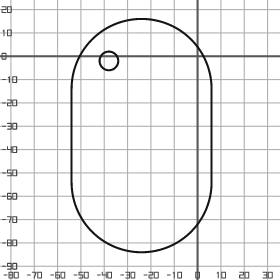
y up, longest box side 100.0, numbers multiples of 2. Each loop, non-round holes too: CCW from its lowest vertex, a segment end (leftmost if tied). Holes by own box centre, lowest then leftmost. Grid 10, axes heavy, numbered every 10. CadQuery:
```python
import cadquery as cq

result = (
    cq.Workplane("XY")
    .moveTo(-54.0, -54.0)
    .threePointArc((-24.0, -84.0), (6.0, -54.0))
    .lineTo(6.0, -14.0)
    .threePointArc((-24.0, 16.0), (-54.0, -14.0))
    .close()
    .moveTo(-38.0, -2.0)
    .circle(4.0)
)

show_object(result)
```